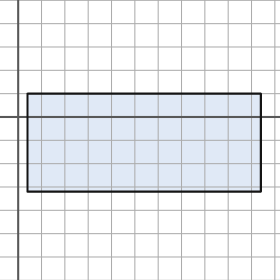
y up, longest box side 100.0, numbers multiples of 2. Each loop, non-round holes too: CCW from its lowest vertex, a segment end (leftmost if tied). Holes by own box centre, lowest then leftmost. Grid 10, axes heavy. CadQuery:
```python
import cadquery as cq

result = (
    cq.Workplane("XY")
    .moveTo(4.0, -32.0)
    .lineTo(104.0, -32.0)
    .lineTo(104.0, 10.0)
    .lineTo(4.0, 10.0)
    .close()
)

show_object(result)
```